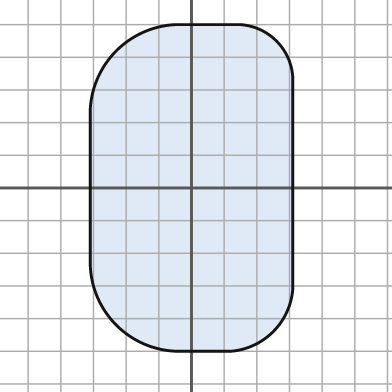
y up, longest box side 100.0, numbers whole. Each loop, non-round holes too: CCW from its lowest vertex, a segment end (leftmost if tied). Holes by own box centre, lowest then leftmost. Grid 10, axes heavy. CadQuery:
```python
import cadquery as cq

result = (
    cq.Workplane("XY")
    .moveTo(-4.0, -50.0)
    .lineTo(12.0, -50.0)
    .threePointArc((25.0, -44.0), (31.0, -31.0))
    .lineTo(31.0, 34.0)
    .threePointArc((26.0, 45.0), (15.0, 50.0))
    .lineTo(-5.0, 50.0)
    .threePointArc((-23.0, 42.0), (-31.0, 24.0))
    .lineTo(-31.0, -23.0)
    .threePointArc((-23.0, -42.0), (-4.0, -50.0))
    .close()
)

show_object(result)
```